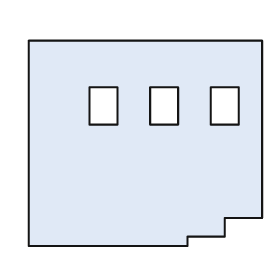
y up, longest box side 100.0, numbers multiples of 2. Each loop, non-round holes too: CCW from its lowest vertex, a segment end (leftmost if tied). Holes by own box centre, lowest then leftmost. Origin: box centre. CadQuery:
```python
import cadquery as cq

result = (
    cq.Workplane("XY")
    .moveTo(-50.0, -44.0)
    .lineTo(18.0, -44.0)
    .lineTo(18.0, -40.0)
    .lineTo(34.0, -40.0)
    .lineTo(34.0, -32.0)
    .lineTo(50.0, -32.0)
    .lineTo(50.0, 44.0)
    .lineTo(-50.0, 44.0)
    .close()
    .moveTo(-24.0, 8.0)
    .lineTo(-12.0, 8.0)
    .lineTo(-12.0, 24.0)
    .lineTo(-24.0, 24.0)
    .close()
    .moveTo(2.0, 8.0)
    .lineTo(14.0, 8.0)
    .lineTo(14.0, 24.0)
    .lineTo(2.0, 24.0)
    .close()
    .moveTo(28.0, 8.0)
    .lineTo(40.0, 8.0)
    .lineTo(40.0, 24.0)
    .lineTo(28.0, 24.0)
    .close()
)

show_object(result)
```